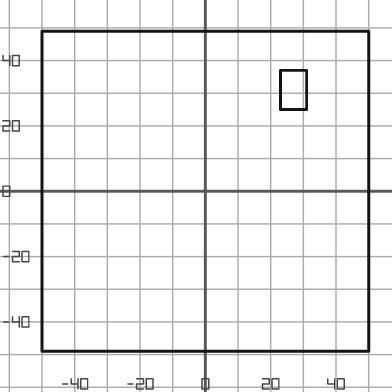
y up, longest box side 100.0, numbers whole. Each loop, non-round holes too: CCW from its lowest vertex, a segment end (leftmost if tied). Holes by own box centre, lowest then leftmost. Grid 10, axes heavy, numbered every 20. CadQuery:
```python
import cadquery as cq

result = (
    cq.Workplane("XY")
    .moveTo(-50.0, -49.0)
    .lineTo(50.0, -49.0)
    .lineTo(50.0, 49.0)
    .lineTo(-50.0, 49.0)
    .close()
    .moveTo(23.0, 25.0)
    .lineTo(31.0, 25.0)
    .lineTo(31.0, 37.0)
    .lineTo(23.0, 37.0)
    .close()
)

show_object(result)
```